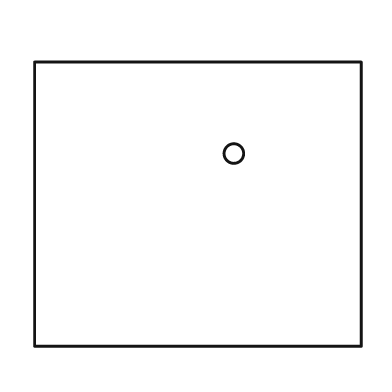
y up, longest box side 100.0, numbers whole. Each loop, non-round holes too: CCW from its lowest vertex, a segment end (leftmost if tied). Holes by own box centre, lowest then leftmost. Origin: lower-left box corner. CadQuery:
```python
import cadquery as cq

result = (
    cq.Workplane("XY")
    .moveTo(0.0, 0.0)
    .lineTo(100.0, 0.0)
    .lineTo(100.0, 87.0)
    .lineTo(0.0, 87.0)
    .close()
    .moveTo(61.0, 59.0)
    .circle(3.0)
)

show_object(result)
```